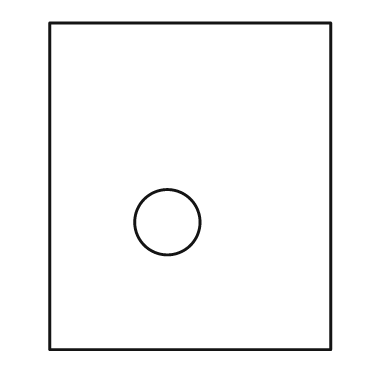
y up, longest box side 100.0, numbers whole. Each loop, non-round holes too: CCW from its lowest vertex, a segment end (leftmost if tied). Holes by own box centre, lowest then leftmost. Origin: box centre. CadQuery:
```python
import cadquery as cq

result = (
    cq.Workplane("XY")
    .moveTo(-43.0, -50.0)
    .lineTo(43.0, -50.0)
    .lineTo(43.0, 50.0)
    .lineTo(-43.0, 50.0)
    .close()
    .moveTo(-7.0, -11.0)
    .circle(10.0)
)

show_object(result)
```